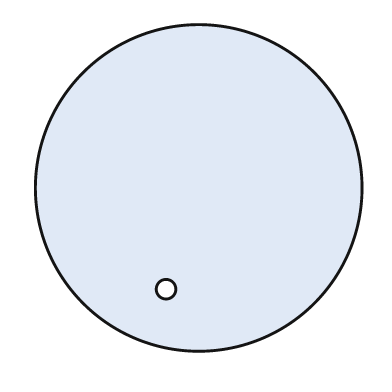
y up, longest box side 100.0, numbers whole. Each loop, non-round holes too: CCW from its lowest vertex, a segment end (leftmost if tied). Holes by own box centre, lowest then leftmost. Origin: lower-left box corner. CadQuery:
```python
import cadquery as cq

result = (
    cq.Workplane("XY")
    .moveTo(50.0, 50.0)
    .circle(50.0)
    .moveTo(40.0, 19.0)
    .circle(3.0)
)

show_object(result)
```